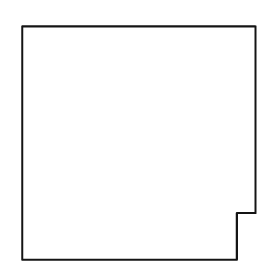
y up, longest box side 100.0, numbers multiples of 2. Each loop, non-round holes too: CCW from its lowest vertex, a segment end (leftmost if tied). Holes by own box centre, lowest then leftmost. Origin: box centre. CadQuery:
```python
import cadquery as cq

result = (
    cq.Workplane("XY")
    .moveTo(-50.0, -50.0)
    .lineTo(42.0, -50.0)
    .lineTo(42.0, -30.0)
    .lineTo(50.0, -30.0)
    .lineTo(50.0, 50.0)
    .lineTo(-50.0, 50.0)
    .close()
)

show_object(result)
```